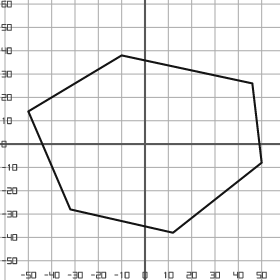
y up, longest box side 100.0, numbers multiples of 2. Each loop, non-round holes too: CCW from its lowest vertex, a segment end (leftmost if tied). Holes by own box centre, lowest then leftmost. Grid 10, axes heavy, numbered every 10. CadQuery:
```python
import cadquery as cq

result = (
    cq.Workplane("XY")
    .moveTo(12.0, -38.0)
    .lineTo(50.0, -8.0)
    .lineTo(46.0, 26.0)
    .lineTo(-10.0, 38.0)
    .lineTo(-50.0, 14.0)
    .lineTo(-32.0, -28.0)
    .close()
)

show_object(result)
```